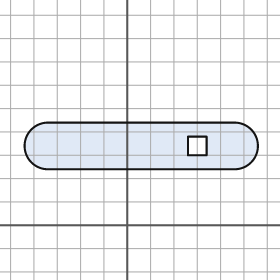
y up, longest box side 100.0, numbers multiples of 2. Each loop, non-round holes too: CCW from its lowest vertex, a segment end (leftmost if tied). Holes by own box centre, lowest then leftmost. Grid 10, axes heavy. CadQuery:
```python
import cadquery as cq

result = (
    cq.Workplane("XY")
    .moveTo(-34.0, 24.0)
    .lineTo(46.0, 24.0)
    .threePointArc((56.0, 34.0), (46.0, 44.0))
    .lineTo(-34.0, 44.0)
    .threePointArc((-44.0, 34.0), (-34.0, 24.0))
    .close()
    .moveTo(26.0, 30.0)
    .lineTo(34.0, 30.0)
    .lineTo(34.0, 38.0)
    .lineTo(26.0, 38.0)
    .close()
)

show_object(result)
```